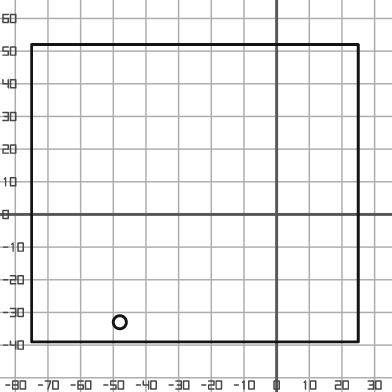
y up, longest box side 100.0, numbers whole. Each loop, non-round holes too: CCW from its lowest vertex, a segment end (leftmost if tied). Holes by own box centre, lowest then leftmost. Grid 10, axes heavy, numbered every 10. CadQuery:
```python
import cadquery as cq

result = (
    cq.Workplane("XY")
    .moveTo(-75.0, -39.0)
    .lineTo(25.0, -39.0)
    .lineTo(25.0, 52.0)
    .lineTo(-75.0, 52.0)
    .close()
    .moveTo(-48.0, -33.0)
    .circle(2.0)
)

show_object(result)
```